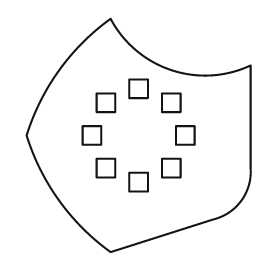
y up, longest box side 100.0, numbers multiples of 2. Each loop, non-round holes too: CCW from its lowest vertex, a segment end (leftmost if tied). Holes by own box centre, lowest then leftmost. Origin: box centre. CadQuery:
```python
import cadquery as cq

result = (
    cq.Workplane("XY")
    .moveTo(-12.0, -50.0)
    .lineTo(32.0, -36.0)
    .threePointArc((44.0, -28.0), (48.0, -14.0))
    .lineTo(48.0, 30.0)
    .threePointArc((14.0, 28.0), (-12.0, 50.0))
    .threePointArc((-34.0, 28.0), (-48.0, 0.0))
    .threePointArc((-34.0, -28.0), (-12.0, -50.0))
    .close()
    .moveTo(-4.0, -24.0)
    .lineTo(4.0, -24.0)
    .lineTo(4.0, -16.0)
    .lineTo(-4.0, -16.0)
    .close()
    .moveTo(-18.0, -18.0)
    .lineTo(-10.0, -18.0)
    .lineTo(-10.0, -10.0)
    .lineTo(-18.0, -10.0)
    .close()
    .moveTo(10.0, -18.0)
    .lineTo(18.0, -18.0)
    .lineTo(18.0, -10.0)
    .lineTo(10.0, -10.0)
    .close()
    .moveTo(-24.0, -4.0)
    .lineTo(-16.0, -4.0)
    .lineTo(-16.0, 4.0)
    .lineTo(-24.0, 4.0)
    .close()
    .moveTo(16.0, -4.0)
    .lineTo(24.0, -4.0)
    .lineTo(24.0, 4.0)
    .lineTo(16.0, 4.0)
    .close()
    .moveTo(-18.0, 10.0)
    .lineTo(-10.0, 10.0)
    .lineTo(-10.0, 18.0)
    .lineTo(-18.0, 18.0)
    .close()
    .moveTo(10.0, 10.0)
    .lineTo(18.0, 10.0)
    .lineTo(18.0, 18.0)
    .lineTo(10.0, 18.0)
    .close()
    .moveTo(-4.0, 16.0)
    .lineTo(4.0, 16.0)
    .lineTo(4.0, 24.0)
    .lineTo(-4.0, 24.0)
    .close()
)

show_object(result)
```